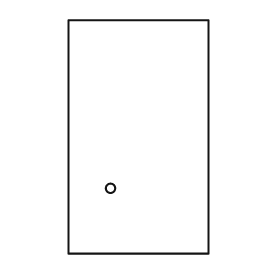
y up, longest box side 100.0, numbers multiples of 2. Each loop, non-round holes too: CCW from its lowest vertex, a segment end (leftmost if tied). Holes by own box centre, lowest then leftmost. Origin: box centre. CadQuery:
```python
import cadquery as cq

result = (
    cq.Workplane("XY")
    .moveTo(-30.0, -50.0)
    .lineTo(30.0, -50.0)
    .lineTo(30.0, 50.0)
    .lineTo(-30.0, 50.0)
    .close()
    .moveTo(-12.0, -22.0)
    .circle(2.0)
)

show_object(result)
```